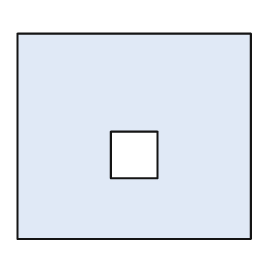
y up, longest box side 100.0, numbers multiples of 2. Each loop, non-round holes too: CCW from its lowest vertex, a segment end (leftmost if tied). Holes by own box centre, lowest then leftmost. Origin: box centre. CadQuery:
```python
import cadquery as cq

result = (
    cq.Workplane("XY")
    .moveTo(-50.0, -44.0)
    .lineTo(50.0, -44.0)
    .lineTo(50.0, 44.0)
    .lineTo(-50.0, 44.0)
    .close()
    .moveTo(-10.0, -18.0)
    .lineTo(10.0, -18.0)
    .lineTo(10.0, 2.0)
    .lineTo(-10.0, 2.0)
    .close()
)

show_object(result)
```